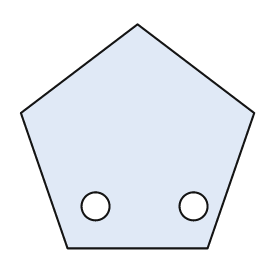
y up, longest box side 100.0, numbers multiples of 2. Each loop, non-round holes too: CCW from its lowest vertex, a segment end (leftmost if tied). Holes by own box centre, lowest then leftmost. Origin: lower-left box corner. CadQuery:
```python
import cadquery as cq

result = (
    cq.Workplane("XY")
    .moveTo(20.0, 0.0)
    .lineTo(80.0, 0.0)
    .lineTo(100.0, 58.0)
    .lineTo(50.0, 96.0)
    .lineTo(0.0, 58.0)
    .close()
    .moveTo(32.0, 18.0)
    .circle(6.0)
    .moveTo(74.0, 18.0)
    .circle(6.0)
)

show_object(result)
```